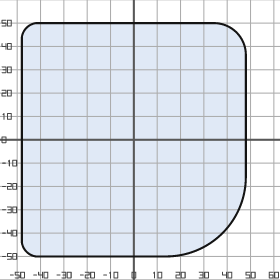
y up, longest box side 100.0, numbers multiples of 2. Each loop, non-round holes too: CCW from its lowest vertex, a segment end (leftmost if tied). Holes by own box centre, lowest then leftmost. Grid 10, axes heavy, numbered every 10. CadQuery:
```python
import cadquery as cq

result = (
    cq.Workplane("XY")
    .moveTo(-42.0, -50.0)
    .lineTo(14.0, -50.0)
    .threePointArc((38.0, -40.0), (48.0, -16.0))
    .lineTo(48.0, 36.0)
    .threePointArc((44.0, 46.0), (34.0, 50.0))
    .lineTo(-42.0, 50.0)
    .threePointArc((-46.0, 48.0), (-48.0, 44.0))
    .lineTo(-48.0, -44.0)
    .threePointArc((-46.0, -48.0), (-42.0, -50.0))
    .close()
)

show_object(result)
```